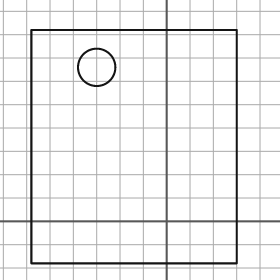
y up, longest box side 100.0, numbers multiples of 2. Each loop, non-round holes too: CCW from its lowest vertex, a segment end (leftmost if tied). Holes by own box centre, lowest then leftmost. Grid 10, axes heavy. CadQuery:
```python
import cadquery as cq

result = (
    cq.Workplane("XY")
    .moveTo(-58.0, -18.0)
    .lineTo(30.0, -18.0)
    .lineTo(30.0, 82.0)
    .lineTo(-58.0, 82.0)
    .close()
    .moveTo(-30.0, 66.0)
    .circle(8.0)
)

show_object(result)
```